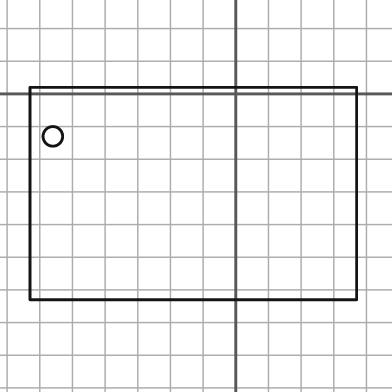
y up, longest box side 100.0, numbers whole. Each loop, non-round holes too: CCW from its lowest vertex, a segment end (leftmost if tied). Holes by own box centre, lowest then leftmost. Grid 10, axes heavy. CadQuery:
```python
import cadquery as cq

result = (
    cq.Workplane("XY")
    .moveTo(-63.0, -63.0)
    .lineTo(37.0, -63.0)
    .lineTo(37.0, 2.0)
    .lineTo(-63.0, 2.0)
    .close()
    .moveTo(-56.0, -13.0)
    .circle(3.0)
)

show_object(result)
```